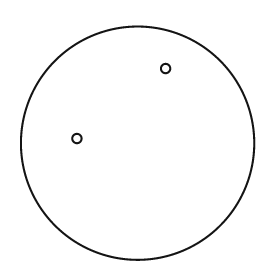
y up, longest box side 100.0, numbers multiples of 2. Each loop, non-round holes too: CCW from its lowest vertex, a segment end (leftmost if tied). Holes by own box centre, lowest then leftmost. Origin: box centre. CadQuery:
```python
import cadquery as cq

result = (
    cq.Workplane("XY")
    .moveTo(0.0, 0.0)
    .circle(50.0)
    .moveTo(-26.0, 2.0)
    .circle(2.0)
    .moveTo(12.0, 32.0)
    .circle(2.0)
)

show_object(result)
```